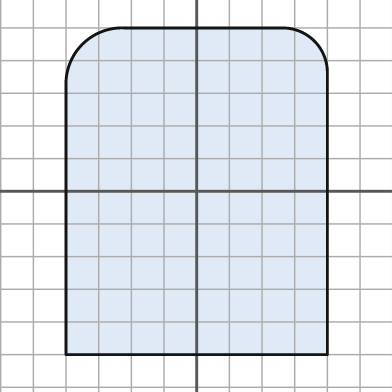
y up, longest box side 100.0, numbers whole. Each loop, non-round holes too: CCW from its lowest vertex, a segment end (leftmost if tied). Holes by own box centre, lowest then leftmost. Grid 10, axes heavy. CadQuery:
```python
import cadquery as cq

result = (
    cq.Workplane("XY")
    .moveTo(-40.0, -50.0)
    .lineTo(40.0, -50.0)
    .lineTo(40.0, 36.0)
    .threePointArc((36.0, 46.0), (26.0, 50.0))
    .lineTo(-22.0, 50.0)
    .threePointArc((-35.0, 45.0), (-40.0, 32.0))
    .close()
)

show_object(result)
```